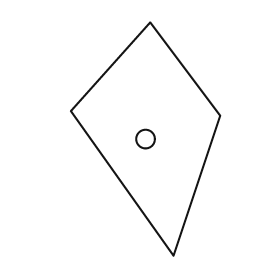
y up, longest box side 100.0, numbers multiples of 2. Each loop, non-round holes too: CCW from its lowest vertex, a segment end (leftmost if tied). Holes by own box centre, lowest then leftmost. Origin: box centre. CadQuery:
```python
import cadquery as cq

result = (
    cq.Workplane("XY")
    .moveTo(12.0, -50.0)
    .lineTo(32.0, 10.0)
    .lineTo(2.0, 50.0)
    .lineTo(-32.0, 12.0)
    .close()
    .moveTo(0.0, 0.0)
    .circle(4.0)
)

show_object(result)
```